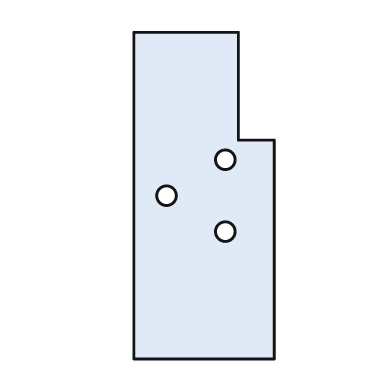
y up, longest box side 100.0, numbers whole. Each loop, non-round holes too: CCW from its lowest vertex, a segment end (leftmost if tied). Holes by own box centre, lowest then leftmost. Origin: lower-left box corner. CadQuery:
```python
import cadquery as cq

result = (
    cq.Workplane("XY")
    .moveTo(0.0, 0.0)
    .lineTo(43.0, 0.0)
    .lineTo(43.0, 67.0)
    .lineTo(32.0, 67.0)
    .lineTo(32.0, 100.0)
    .lineTo(0.0, 100.0)
    .close()
    .moveTo(28.0, 39.0)
    .circle(3.0)
    .moveTo(10.0, 50.0)
    .circle(3.0)
    .moveTo(28.0, 61.0)
    .circle(3.0)
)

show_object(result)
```